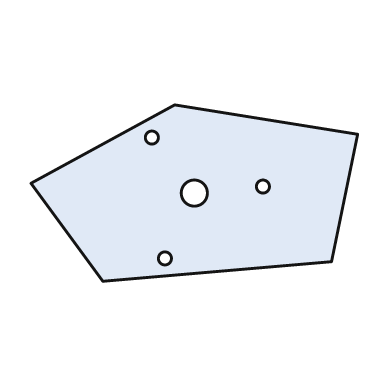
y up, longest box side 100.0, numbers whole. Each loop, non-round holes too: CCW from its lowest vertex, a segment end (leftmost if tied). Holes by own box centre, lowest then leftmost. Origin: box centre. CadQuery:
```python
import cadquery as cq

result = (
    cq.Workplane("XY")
    .moveTo(-28.0, -27.0)
    .lineTo(42.0, -21.0)
    .lineTo(50.0, 18.0)
    .lineTo(-6.0, 27.0)
    .lineTo(-50.0, 3.0)
    .close()
    .moveTo(-9.0, -20.0)
    .circle(2.0)
    .moveTo(0.0, 0.0)
    .circle(4.0)
    .moveTo(21.0, 2.0)
    .circle(2.0)
    .moveTo(-13.0, 17.0)
    .circle(2.0)
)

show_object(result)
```